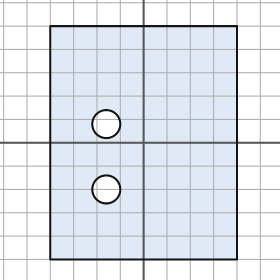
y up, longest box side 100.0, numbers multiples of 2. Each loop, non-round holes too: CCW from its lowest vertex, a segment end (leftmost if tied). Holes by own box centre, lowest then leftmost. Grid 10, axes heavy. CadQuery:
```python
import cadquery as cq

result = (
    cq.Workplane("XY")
    .moveTo(-40.0, -50.0)
    .lineTo(40.0, -50.0)
    .lineTo(40.0, 50.0)
    .lineTo(-40.0, 50.0)
    .close()
    .moveTo(-16.0, -20.0)
    .circle(6.0)
    .moveTo(-16.0, 8.0)
    .circle(6.0)
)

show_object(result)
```